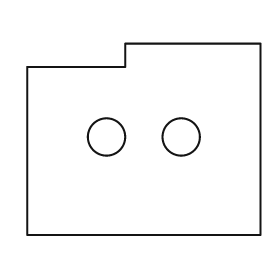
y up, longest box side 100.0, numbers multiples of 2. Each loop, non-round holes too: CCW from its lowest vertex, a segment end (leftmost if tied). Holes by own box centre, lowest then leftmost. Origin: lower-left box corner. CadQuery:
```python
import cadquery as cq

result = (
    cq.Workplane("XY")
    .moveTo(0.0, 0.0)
    .lineTo(100.0, 0.0)
    .lineTo(100.0, 82.0)
    .lineTo(42.0, 82.0)
    .lineTo(42.0, 72.0)
    .lineTo(0.0, 72.0)
    .close()
    .moveTo(34.0, 42.0)
    .circle(8.0)
    .moveTo(66.0, 42.0)
    .circle(8.0)
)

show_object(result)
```